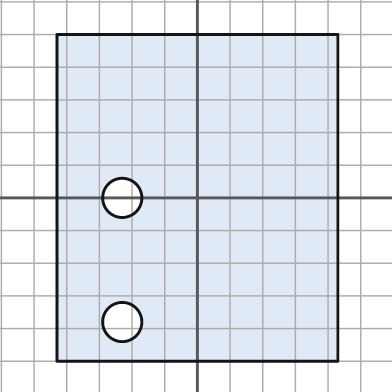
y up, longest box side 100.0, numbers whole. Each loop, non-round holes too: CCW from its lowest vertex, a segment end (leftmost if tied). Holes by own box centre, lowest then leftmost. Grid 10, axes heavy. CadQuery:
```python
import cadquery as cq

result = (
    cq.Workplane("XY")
    .moveTo(-43.0, -50.0)
    .lineTo(43.0, -50.0)
    .lineTo(43.0, 50.0)
    .lineTo(-43.0, 50.0)
    .close()
    .moveTo(-23.0, -38.0)
    .circle(6.0)
    .moveTo(-23.0, 0.0)
    .circle(6.0)
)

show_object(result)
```